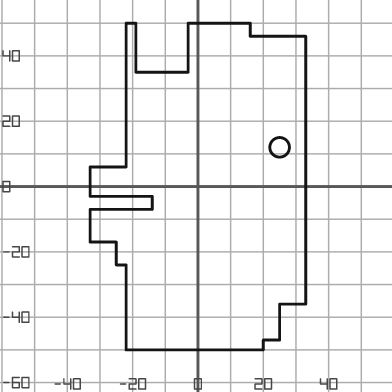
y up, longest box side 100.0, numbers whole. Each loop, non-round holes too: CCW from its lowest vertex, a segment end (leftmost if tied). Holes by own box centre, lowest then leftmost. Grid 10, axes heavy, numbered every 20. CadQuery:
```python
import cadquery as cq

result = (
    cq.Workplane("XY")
    .moveTo(-22.0, -50.0)
    .lineTo(20.0, -50.0)
    .lineTo(20.0, -47.0)
    .lineTo(25.0, -47.0)
    .lineTo(25.0, -36.0)
    .lineTo(33.0, -36.0)
    .lineTo(33.0, 46.0)
    .lineTo(16.0, 46.0)
    .lineTo(16.0, 50.0)
    .lineTo(-3.0, 50.0)
    .lineTo(-3.0, 35.0)
    .lineTo(-19.0, 35.0)
    .lineTo(-19.0, 50.0)
    .lineTo(-22.0, 50.0)
    .lineTo(-22.0, 6.0)
    .lineTo(-33.0, 6.0)
    .lineTo(-33.0, -3.0)
    .lineTo(-14.0, -3.0)
    .lineTo(-14.0, -7.0)
    .lineTo(-33.0, -7.0)
    .lineTo(-33.0, -17.0)
    .lineTo(-25.0, -17.0)
    .lineTo(-25.0, -24.0)
    .lineTo(-22.0, -24.0)
    .close()
    .moveTo(25.0, 12.0)
    .circle(3.0)
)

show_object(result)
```